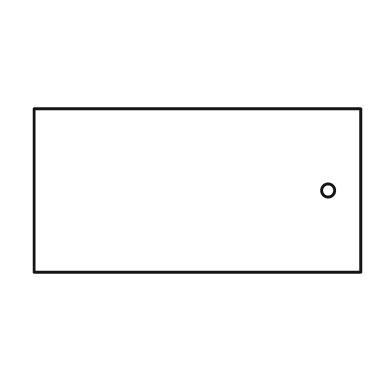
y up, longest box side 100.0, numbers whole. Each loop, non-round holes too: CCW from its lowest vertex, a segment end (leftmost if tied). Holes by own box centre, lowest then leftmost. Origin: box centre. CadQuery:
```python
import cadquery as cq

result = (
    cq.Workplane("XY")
    .moveTo(-50.0, -25.0)
    .lineTo(50.0, -25.0)
    .lineTo(50.0, 25.0)
    .lineTo(-50.0, 25.0)
    .close()
    .moveTo(40.0, 0.0)
    .circle(2.0)
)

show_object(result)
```